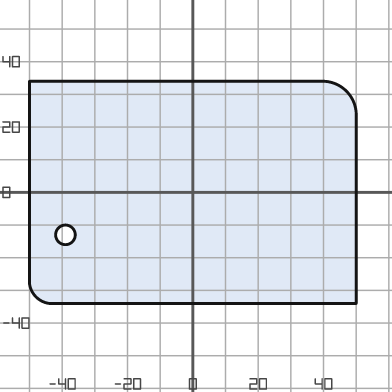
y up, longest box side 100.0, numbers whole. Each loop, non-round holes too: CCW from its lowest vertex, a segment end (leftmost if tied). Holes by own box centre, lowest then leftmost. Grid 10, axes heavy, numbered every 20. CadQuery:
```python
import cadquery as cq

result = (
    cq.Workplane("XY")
    .moveTo(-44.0, -34.0)
    .lineTo(50.0, -34.0)
    .lineTo(50.0, 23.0)
    .threePointArc((47.0, 31.0), (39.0, 34.0))
    .lineTo(-50.0, 34.0)
    .lineTo(-50.0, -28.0)
    .threePointArc((-48.0, -32.0), (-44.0, -34.0))
    .close()
    .moveTo(-39.0, -13.0)
    .circle(3.0)
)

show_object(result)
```